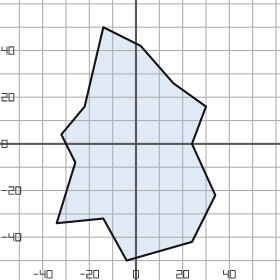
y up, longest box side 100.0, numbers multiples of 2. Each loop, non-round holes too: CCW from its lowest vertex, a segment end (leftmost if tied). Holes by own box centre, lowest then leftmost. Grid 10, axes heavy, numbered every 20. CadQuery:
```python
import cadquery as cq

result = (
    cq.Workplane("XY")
    .moveTo(-4.0, -50.0)
    .lineTo(24.0, -42.0)
    .lineTo(34.0, -22.0)
    .lineTo(24.0, 0.0)
    .lineTo(30.0, 16.0)
    .lineTo(16.0, 26.0)
    .lineTo(2.0, 42.0)
    .lineTo(-14.0, 50.0)
    .lineTo(-22.0, 16.0)
    .lineTo(-32.0, 4.0)
    .lineTo(-26.0, -8.0)
    .lineTo(-34.0, -34.0)
    .lineTo(-14.0, -32.0)
    .close()
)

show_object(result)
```